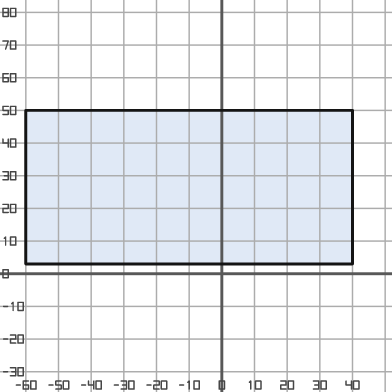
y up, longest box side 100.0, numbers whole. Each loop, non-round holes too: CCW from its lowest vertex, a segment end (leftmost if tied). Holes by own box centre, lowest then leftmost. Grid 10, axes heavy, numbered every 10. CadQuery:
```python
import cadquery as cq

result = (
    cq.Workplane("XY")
    .moveTo(-60.0, 3.0)
    .lineTo(40.0, 3.0)
    .lineTo(40.0, 50.0)
    .lineTo(-60.0, 50.0)
    .close()
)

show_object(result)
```